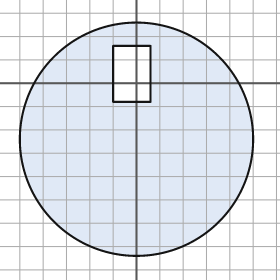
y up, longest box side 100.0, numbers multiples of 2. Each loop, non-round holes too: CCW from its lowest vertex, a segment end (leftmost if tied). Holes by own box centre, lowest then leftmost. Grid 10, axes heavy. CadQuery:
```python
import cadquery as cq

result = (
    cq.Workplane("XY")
    .moveTo(0.0, -24.0)
    .circle(50.0)
    .moveTo(-10.0, -8.0)
    .lineTo(6.0, -8.0)
    .lineTo(6.0, 16.0)
    .lineTo(-10.0, 16.0)
    .close()
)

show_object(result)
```